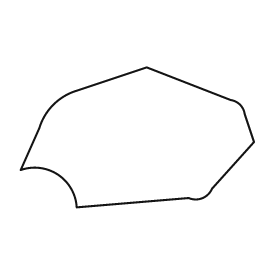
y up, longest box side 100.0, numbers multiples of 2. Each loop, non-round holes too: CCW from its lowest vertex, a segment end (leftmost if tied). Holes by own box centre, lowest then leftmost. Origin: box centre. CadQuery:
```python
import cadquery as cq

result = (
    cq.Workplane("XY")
    .moveTo(-26.0, -30.0)
    .lineTo(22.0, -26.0)
    .threePointArc((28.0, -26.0), (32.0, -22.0))
    .lineTo(50.0, -2.0)
    .lineTo(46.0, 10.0)
    .threePointArc((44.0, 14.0), (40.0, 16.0))
    .lineTo(4.0, 30.0)
    .lineTo(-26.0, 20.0)
    .threePointArc((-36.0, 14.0), (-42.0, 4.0))
    .lineTo(-50.0, -14.0)
    .threePointArc((-34.0, -16.0), (-26.0, -30.0))
    .close()
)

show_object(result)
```